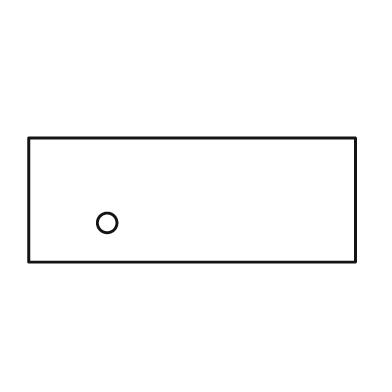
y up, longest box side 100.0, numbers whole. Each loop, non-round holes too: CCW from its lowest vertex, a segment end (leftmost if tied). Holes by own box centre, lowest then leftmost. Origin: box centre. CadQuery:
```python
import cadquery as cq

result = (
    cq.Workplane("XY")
    .moveTo(-50.0, -19.0)
    .lineTo(50.0, -19.0)
    .lineTo(50.0, 19.0)
    .lineTo(-50.0, 19.0)
    .close()
    .moveTo(-26.0, -7.0)
    .circle(3.0)
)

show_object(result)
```